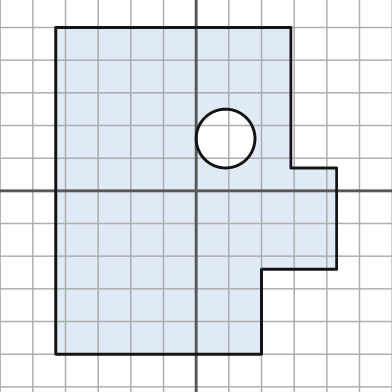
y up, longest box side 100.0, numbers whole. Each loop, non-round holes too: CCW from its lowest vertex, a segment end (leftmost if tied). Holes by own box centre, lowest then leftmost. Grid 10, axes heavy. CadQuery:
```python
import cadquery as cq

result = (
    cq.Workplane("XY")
    .moveTo(-43.0, -50.0)
    .lineTo(20.0, -50.0)
    .lineTo(20.0, -24.0)
    .lineTo(43.0, -24.0)
    .lineTo(43.0, 7.0)
    .lineTo(29.0, 7.0)
    .lineTo(29.0, 50.0)
    .lineTo(-43.0, 50.0)
    .close()
    .moveTo(9.0, 16.0)
    .circle(9.0)
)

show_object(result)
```